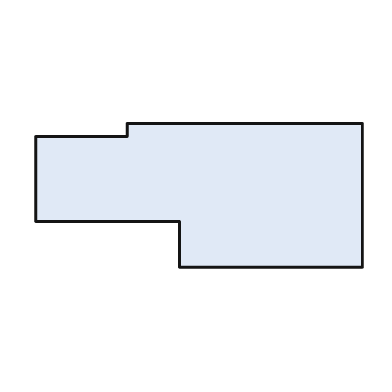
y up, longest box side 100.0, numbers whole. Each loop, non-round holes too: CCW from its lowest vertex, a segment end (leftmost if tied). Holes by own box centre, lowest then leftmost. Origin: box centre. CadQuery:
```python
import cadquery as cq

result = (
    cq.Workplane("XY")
    .moveTo(-6.0, -22.0)
    .lineTo(50.0, -22.0)
    .lineTo(50.0, 22.0)
    .lineTo(-22.0, 22.0)
    .lineTo(-22.0, 18.0)
    .lineTo(-50.0, 18.0)
    .lineTo(-50.0, -8.0)
    .lineTo(-6.0, -8.0)
    .close()
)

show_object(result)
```